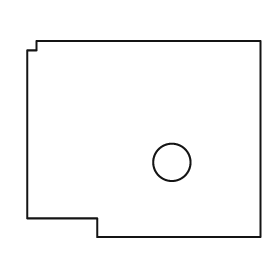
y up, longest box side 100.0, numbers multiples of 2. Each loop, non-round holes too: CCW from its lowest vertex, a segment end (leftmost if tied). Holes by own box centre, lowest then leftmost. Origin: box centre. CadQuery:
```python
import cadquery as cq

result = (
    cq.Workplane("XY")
    .moveTo(-20.0, -42.0)
    .lineTo(50.0, -42.0)
    .lineTo(50.0, 42.0)
    .lineTo(-46.0, 42.0)
    .lineTo(-46.0, 38.0)
    .lineTo(-50.0, 38.0)
    .lineTo(-50.0, -34.0)
    .lineTo(-20.0, -34.0)
    .close()
    .moveTo(12.0, -10.0)
    .circle(8.0)
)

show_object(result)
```